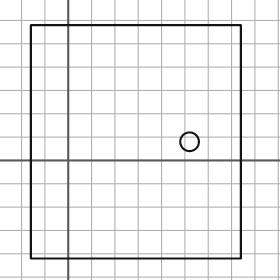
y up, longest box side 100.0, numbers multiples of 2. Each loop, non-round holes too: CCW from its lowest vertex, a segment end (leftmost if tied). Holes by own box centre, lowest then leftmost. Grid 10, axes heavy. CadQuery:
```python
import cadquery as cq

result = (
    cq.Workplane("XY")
    .moveTo(-16.0, -42.0)
    .lineTo(74.0, -42.0)
    .lineTo(74.0, 58.0)
    .lineTo(-16.0, 58.0)
    .close()
    .moveTo(52.0, 8.0)
    .circle(4.0)
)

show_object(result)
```